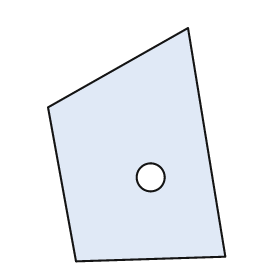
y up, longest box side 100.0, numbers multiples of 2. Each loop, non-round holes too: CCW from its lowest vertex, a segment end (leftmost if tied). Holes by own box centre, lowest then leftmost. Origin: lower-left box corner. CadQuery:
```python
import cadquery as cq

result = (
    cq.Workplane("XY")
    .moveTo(12.0, 0.0)
    .lineTo(76.0, 2.0)
    .lineTo(60.0, 100.0)
    .lineTo(0.0, 66.0)
    .close()
    .moveTo(44.0, 36.0)
    .circle(6.0)
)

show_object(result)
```